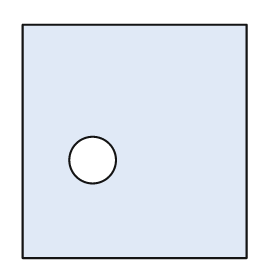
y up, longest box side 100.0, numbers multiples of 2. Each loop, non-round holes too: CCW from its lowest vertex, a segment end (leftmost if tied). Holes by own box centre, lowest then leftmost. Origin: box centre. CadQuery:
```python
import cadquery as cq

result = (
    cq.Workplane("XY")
    .moveTo(-48.0, -50.0)
    .lineTo(48.0, -50.0)
    .lineTo(48.0, 50.0)
    .lineTo(-48.0, 50.0)
    .close()
    .moveTo(-18.0, -8.0)
    .circle(10.0)
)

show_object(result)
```